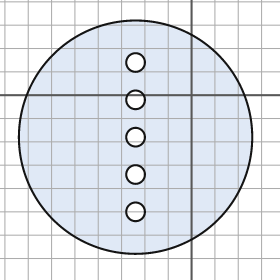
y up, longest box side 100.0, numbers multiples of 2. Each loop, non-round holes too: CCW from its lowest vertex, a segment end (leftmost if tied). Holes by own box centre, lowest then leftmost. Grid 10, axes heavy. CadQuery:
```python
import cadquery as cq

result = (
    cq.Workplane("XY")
    .moveTo(-24.0, -18.0)
    .circle(50.0)
    .moveTo(-24.0, -50.0)
    .circle(4.0)
    .moveTo(-24.0, -34.0)
    .circle(4.0)
    .moveTo(-24.0, -18.0)
    .circle(4.0)
    .moveTo(-24.0, -2.0)
    .circle(4.0)
    .moveTo(-24.0, 14.0)
    .circle(4.0)
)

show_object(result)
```